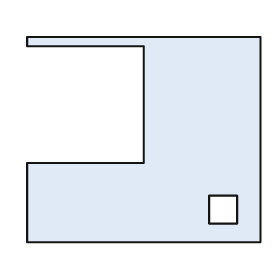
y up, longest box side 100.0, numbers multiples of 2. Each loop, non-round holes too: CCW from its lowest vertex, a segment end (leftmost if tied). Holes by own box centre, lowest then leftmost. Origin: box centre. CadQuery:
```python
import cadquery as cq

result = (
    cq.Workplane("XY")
    .moveTo(-50.0, -44.0)
    .lineTo(50.0, -44.0)
    .lineTo(50.0, 44.0)
    .lineTo(-50.0, 44.0)
    .lineTo(-50.0, 40.0)
    .lineTo(0.0, 40.0)
    .lineTo(0.0, -10.0)
    .lineTo(-50.0, -10.0)
    .close()
    .moveTo(28.0, -36.0)
    .lineTo(40.0, -36.0)
    .lineTo(40.0, -24.0)
    .lineTo(28.0, -24.0)
    .close()
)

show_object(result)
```